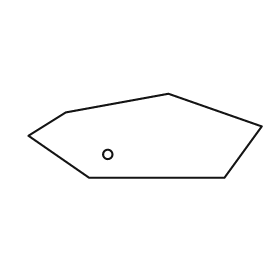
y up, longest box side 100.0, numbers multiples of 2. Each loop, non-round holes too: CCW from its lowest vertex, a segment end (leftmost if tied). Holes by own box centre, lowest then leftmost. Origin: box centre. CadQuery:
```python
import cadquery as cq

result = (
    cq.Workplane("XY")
    .moveTo(-24.0, -18.0)
    .lineTo(34.0, -18.0)
    .lineTo(50.0, 4.0)
    .lineTo(10.0, 18.0)
    .lineTo(-34.0, 10.0)
    .lineTo(-50.0, 0.0)
    .close()
    .moveTo(-16.0, -8.0)
    .circle(2.0)
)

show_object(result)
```